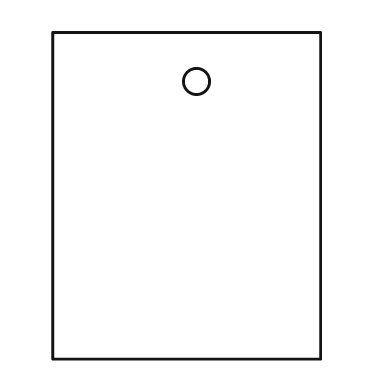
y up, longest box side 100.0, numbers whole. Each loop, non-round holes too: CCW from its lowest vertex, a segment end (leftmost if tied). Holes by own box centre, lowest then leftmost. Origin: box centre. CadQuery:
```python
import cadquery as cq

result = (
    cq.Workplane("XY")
    .moveTo(-41.0, -50.0)
    .lineTo(41.0, -50.0)
    .lineTo(41.0, 50.0)
    .lineTo(-41.0, 50.0)
    .close()
    .moveTo(3.0, 35.0)
    .circle(4.0)
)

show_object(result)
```